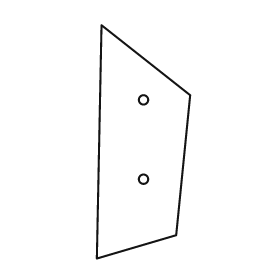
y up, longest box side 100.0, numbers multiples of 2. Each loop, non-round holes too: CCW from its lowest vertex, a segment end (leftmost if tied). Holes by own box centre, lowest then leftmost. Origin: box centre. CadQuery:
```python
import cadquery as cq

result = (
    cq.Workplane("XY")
    .moveTo(-20.0, -50.0)
    .lineTo(14.0, -40.0)
    .lineTo(20.0, 20.0)
    .lineTo(-18.0, 50.0)
    .close()
    .moveTo(0.0, -16.0)
    .circle(2.0)
    .moveTo(0.0, 18.0)
    .circle(2.0)
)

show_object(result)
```